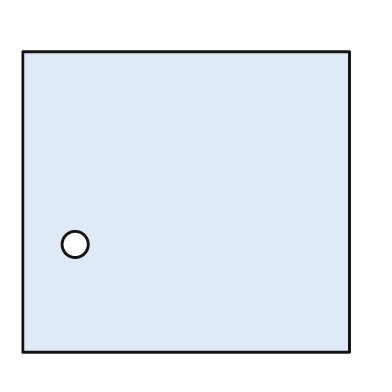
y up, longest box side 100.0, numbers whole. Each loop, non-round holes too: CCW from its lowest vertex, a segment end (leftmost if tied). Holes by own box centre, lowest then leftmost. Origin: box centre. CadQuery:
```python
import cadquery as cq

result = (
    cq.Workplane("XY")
    .moveTo(-50.0, -46.0)
    .lineTo(50.0, -46.0)
    .lineTo(50.0, 46.0)
    .lineTo(-50.0, 46.0)
    .close()
    .moveTo(-34.0, -13.0)
    .circle(4.0)
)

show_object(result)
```